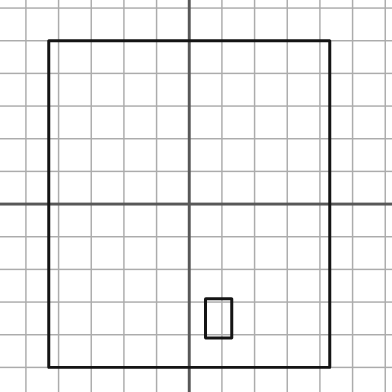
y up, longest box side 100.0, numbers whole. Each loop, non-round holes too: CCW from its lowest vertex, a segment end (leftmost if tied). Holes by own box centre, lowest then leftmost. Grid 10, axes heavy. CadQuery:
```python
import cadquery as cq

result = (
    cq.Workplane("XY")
    .moveTo(-43.0, -50.0)
    .lineTo(43.0, -50.0)
    .lineTo(43.0, 50.0)
    .lineTo(-43.0, 50.0)
    .close()
    .moveTo(5.0, -41.0)
    .lineTo(13.0, -41.0)
    .lineTo(13.0, -29.0)
    .lineTo(5.0, -29.0)
    .close()
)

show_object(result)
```